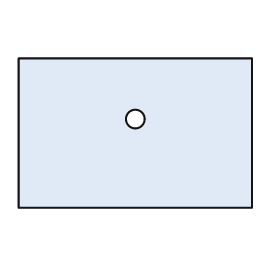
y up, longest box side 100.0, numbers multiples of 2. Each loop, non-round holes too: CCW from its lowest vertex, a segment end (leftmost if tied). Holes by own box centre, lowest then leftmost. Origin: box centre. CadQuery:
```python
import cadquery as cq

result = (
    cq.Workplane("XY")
    .moveTo(-50.0, -32.0)
    .lineTo(50.0, -32.0)
    .lineTo(50.0, 32.0)
    .lineTo(-50.0, 32.0)
    .close()
    .moveTo(0.0, 6.0)
    .circle(4.0)
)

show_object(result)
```